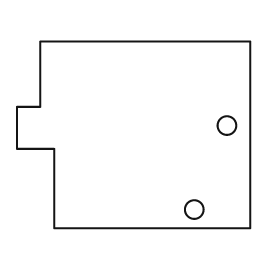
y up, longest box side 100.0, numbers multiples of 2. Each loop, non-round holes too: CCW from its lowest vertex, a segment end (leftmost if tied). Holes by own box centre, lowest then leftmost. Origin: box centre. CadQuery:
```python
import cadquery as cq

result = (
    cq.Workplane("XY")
    .moveTo(-34.0, -40.0)
    .lineTo(50.0, -40.0)
    .lineTo(50.0, 40.0)
    .lineTo(-40.0, 40.0)
    .lineTo(-40.0, 12.0)
    .lineTo(-50.0, 12.0)
    .lineTo(-50.0, -6.0)
    .lineTo(-34.0, -6.0)
    .close()
    .moveTo(26.0, -32.0)
    .circle(4.0)
    .moveTo(40.0, 4.0)
    .circle(4.0)
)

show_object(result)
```